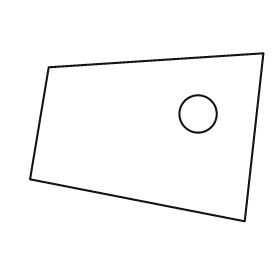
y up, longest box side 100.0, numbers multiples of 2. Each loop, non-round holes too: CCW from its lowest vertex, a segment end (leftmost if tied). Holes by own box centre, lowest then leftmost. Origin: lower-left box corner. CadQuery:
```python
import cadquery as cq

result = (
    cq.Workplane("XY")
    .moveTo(92.0, 0.0)
    .lineTo(100.0, 72.0)
    .lineTo(8.0, 66.0)
    .lineTo(0.0, 18.0)
    .close()
    .moveTo(72.0, 46.0)
    .circle(8.0)
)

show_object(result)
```